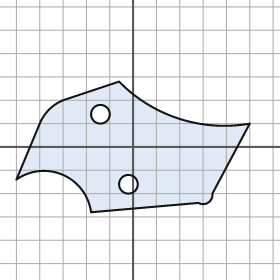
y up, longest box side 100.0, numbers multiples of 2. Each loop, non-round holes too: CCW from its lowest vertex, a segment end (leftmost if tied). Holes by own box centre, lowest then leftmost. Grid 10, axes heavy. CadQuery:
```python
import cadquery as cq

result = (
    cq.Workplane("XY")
    .moveTo(-18.0, -28.0)
    .lineTo(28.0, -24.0)
    .threePointArc((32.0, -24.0), (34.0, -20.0))
    .lineTo(50.0, 10.0)
    .threePointArc((20.0, 12.0), (-6.0, 28.0))
    .lineTo(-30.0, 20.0)
    .threePointArc((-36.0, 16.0), (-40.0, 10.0))
    .lineTo(-50.0, -14.0)
    .threePointArc((-30.0, -12.0), (-18.0, -28.0))
    .close()
    .moveTo(-2.0, -16.0)
    .circle(4.0)
    .moveTo(-14.0, 14.0)
    .circle(4.0)
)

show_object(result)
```